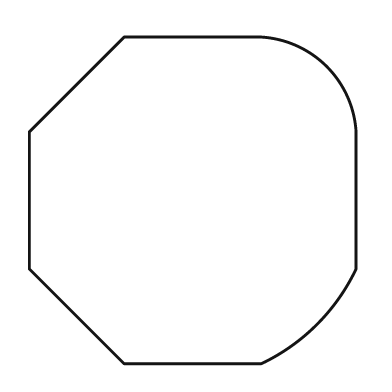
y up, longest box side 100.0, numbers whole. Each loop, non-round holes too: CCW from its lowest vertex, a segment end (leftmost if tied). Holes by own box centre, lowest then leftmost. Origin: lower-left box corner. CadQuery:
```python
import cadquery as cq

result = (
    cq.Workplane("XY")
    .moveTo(29.0, 0.0)
    .lineTo(71.0, 0.0)
    .threePointArc((88.0, 12.0), (100.0, 29.0))
    .lineTo(100.0, 71.0)
    .threePointArc((91.0, 91.0), (71.0, 100.0))
    .lineTo(29.0, 100.0)
    .lineTo(0.0, 71.0)
    .lineTo(0.0, 29.0)
    .close()
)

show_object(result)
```